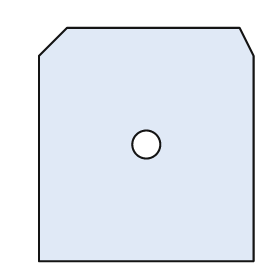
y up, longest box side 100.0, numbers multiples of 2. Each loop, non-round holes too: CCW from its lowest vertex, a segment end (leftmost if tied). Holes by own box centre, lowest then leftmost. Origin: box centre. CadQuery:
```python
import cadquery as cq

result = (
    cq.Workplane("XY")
    .moveTo(-46.0, -50.0)
    .lineTo(46.0, -50.0)
    .lineTo(46.0, 38.0)
    .lineTo(40.0, 50.0)
    .lineTo(-34.0, 50.0)
    .lineTo(-46.0, 38.0)
    .close()
    .moveTo(0.0, 0.0)
    .circle(6.0)
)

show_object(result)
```